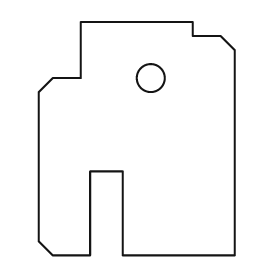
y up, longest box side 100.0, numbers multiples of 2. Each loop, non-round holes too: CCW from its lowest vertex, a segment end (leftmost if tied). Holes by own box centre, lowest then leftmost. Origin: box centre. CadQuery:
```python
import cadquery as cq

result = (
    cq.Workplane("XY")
    .moveTo(-36.0, -50.0)
    .lineTo(-20.0, -50.0)
    .lineTo(-20.0, -14.0)
    .lineTo(-6.0, -14.0)
    .lineTo(-6.0, -50.0)
    .lineTo(42.0, -50.0)
    .lineTo(42.0, 38.0)
    .lineTo(36.0, 44.0)
    .lineTo(24.0, 44.0)
    .lineTo(24.0, 50.0)
    .lineTo(-24.0, 50.0)
    .lineTo(-24.0, 26.0)
    .lineTo(-36.0, 26.0)
    .lineTo(-42.0, 20.0)
    .lineTo(-42.0, -44.0)
    .close()
    .moveTo(6.0, 26.0)
    .circle(6.0)
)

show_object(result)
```